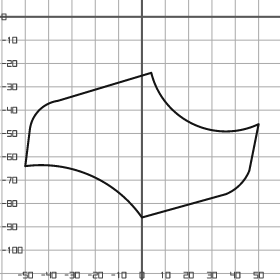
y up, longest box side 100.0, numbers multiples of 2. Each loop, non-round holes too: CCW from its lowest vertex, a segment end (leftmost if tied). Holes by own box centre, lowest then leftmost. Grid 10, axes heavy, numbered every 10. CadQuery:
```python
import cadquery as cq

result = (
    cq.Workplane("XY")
    .moveTo(0.0, -86.0)
    .lineTo(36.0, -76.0)
    .threePointArc((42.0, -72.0), (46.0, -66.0))
    .lineTo(50.0, -46.0)
    .threePointArc((22.0, -46.0), (4.0, -24.0))
    .lineTo(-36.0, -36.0)
    .threePointArc((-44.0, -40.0), (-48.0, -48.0))
    .lineTo(-50.0, -64.0)
    .threePointArc((-22.0, -68.0), (0.0, -86.0))
    .close()
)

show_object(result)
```